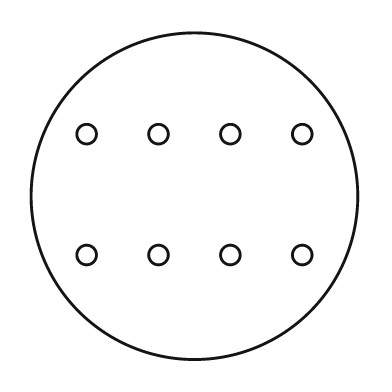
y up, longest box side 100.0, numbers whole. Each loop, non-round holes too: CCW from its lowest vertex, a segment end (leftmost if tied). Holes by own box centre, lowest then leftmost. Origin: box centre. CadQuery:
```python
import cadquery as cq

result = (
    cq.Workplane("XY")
    .moveTo(0.0, 0.0)
    .circle(50.0)
    .moveTo(-33.0, -18.0)
    .circle(3.0)
    .moveTo(-11.0, -18.0)
    .circle(3.0)
    .moveTo(11.0, -18.0)
    .circle(3.0)
    .moveTo(33.0, -18.0)
    .circle(3.0)
    .moveTo(-33.0, 19.0)
    .circle(3.0)
    .moveTo(-11.0, 19.0)
    .circle(3.0)
    .moveTo(11.0, 19.0)
    .circle(3.0)
    .moveTo(33.0, 19.0)
    .circle(3.0)
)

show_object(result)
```